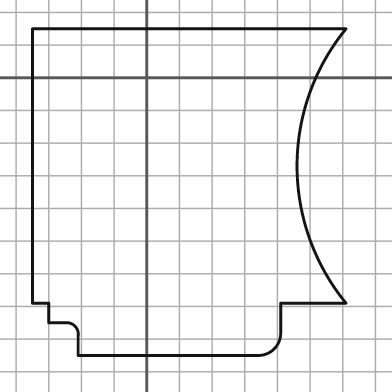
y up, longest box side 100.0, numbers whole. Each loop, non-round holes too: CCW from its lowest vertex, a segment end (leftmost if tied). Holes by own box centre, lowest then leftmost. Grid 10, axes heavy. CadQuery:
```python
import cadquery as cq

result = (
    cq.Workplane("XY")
    .moveTo(-21.0, -85.0)
    .lineTo(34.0, -85.0)
    .threePointArc((39.0, -83.0), (41.0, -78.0))
    .lineTo(41.0, -69.0)
    .lineTo(61.0, -69.0)
    .threePointArc((46.0, -27.0), (61.0, 15.0))
    .lineTo(-35.0, 15.0)
    .lineTo(-35.0, -69.0)
    .lineTo(-30.0, -69.0)
    .lineTo(-30.0, -75.0)
    .lineTo(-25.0, -75.0)
    .threePointArc((-22.0, -76.0), (-21.0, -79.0))
    .close()
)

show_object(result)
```